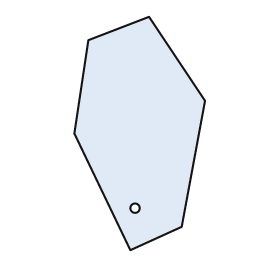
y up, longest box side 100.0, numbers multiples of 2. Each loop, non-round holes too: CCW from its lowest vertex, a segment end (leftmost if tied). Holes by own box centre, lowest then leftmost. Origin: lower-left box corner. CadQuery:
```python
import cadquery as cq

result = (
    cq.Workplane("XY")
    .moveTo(24.0, 0.0)
    .lineTo(46.0, 10.0)
    .lineTo(56.0, 64.0)
    .lineTo(32.0, 100.0)
    .lineTo(6.0, 90.0)
    .lineTo(0.0, 50.0)
    .close()
    .moveTo(26.0, 18.0)
    .circle(2.0)
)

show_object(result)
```